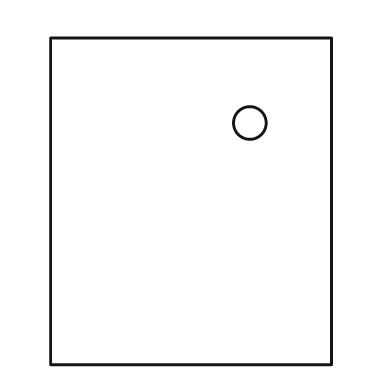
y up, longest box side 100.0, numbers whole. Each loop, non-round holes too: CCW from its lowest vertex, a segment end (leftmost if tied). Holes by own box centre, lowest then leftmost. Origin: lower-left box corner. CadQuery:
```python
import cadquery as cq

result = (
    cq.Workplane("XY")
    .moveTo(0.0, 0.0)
    .lineTo(86.0, 0.0)
    .lineTo(86.0, 100.0)
    .lineTo(0.0, 100.0)
    .close()
    .moveTo(61.0, 74.0)
    .circle(5.0)
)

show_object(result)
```